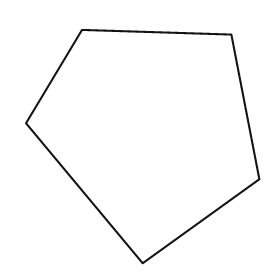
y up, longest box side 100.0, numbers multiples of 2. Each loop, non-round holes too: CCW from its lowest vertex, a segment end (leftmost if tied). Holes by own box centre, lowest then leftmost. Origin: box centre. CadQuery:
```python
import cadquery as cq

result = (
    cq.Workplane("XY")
    .moveTo(0.0, -50.0)
    .lineTo(50.0, -14.0)
    .lineTo(38.0, 48.0)
    .lineTo(-26.0, 50.0)
    .lineTo(-50.0, 10.0)
    .close()
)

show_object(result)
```